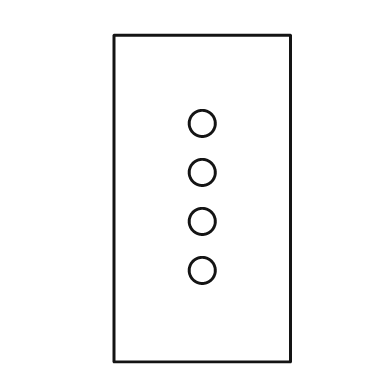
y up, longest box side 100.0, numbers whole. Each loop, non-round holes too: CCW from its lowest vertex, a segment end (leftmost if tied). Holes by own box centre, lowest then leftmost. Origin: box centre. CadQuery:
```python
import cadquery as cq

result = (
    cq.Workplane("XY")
    .moveTo(-27.0, -50.0)
    .lineTo(27.0, -50.0)
    .lineTo(27.0, 50.0)
    .lineTo(-27.0, 50.0)
    .close()
    .moveTo(0.0, -22.0)
    .circle(4.0)
    .moveTo(0.0, -7.0)
    .circle(4.0)
    .moveTo(0.0, 8.0)
    .circle(4.0)
    .moveTo(0.0, 23.0)
    .circle(4.0)
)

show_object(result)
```